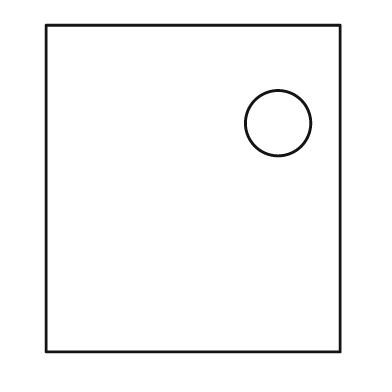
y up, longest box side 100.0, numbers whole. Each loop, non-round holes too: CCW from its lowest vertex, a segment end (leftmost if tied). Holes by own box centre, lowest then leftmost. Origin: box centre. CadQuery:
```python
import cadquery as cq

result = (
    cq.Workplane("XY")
    .moveTo(-45.0, -50.0)
    .lineTo(45.0, -50.0)
    .lineTo(45.0, 50.0)
    .lineTo(-45.0, 50.0)
    .close()
    .moveTo(26.0, 20.0)
    .circle(10.0)
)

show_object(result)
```